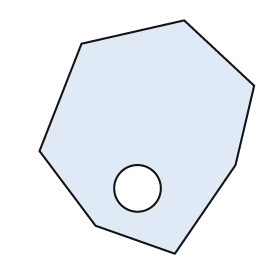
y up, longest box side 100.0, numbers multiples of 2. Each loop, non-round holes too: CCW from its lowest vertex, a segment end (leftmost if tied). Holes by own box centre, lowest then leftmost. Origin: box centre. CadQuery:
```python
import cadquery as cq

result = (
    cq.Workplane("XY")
    .moveTo(12.0, -50.0)
    .lineTo(38.0, -12.0)
    .lineTo(46.0, 22.0)
    .lineTo(16.0, 50.0)
    .lineTo(-28.0, 40.0)
    .lineTo(-46.0, -6.0)
    .lineTo(-22.0, -38.0)
    .close()
    .moveTo(-4.0, -22.0)
    .circle(10.0)
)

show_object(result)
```